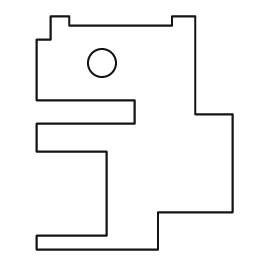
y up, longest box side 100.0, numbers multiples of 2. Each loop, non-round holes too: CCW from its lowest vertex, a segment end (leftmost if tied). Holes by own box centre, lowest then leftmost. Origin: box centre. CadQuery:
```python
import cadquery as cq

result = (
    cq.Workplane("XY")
    .moveTo(-42.0, -50.0)
    .lineTo(10.0, -50.0)
    .lineTo(10.0, -34.0)
    .lineTo(42.0, -34.0)
    .lineTo(42.0, 8.0)
    .lineTo(26.0, 8.0)
    .lineTo(26.0, 50.0)
    .lineTo(16.0, 50.0)
    .lineTo(16.0, 46.0)
    .lineTo(-28.0, 46.0)
    .lineTo(-28.0, 50.0)
    .lineTo(-36.0, 50.0)
    .lineTo(-36.0, 40.0)
    .lineTo(-42.0, 40.0)
    .lineTo(-42.0, 14.0)
    .lineTo(0.0, 14.0)
    .lineTo(0.0, 4.0)
    .lineTo(-42.0, 4.0)
    .lineTo(-42.0, -8.0)
    .lineTo(-12.0, -8.0)
    .lineTo(-12.0, -44.0)
    .lineTo(-42.0, -44.0)
    .close()
    .moveTo(-14.0, 30.0)
    .circle(6.0)
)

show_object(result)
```